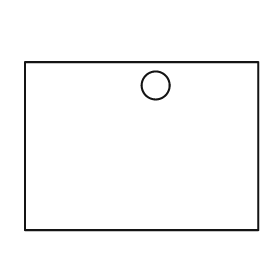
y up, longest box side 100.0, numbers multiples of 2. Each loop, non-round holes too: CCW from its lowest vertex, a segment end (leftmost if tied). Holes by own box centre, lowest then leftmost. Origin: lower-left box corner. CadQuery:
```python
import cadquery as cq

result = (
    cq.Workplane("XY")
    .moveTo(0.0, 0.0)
    .lineTo(100.0, 0.0)
    .lineTo(100.0, 72.0)
    .lineTo(0.0, 72.0)
    .close()
    .moveTo(56.0, 62.0)
    .circle(6.0)
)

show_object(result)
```